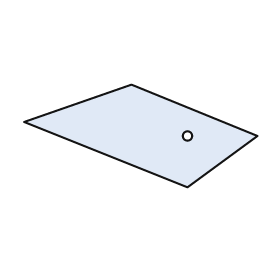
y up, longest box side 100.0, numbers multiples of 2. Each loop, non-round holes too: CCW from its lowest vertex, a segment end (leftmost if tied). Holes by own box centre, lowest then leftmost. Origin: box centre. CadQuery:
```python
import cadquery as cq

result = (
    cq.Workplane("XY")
    .moveTo(20.0, -22.0)
    .lineTo(50.0, 0.0)
    .lineTo(-4.0, 22.0)
    .lineTo(-50.0, 6.0)
    .close()
    .moveTo(20.0, 0.0)
    .circle(2.0)
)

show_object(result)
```